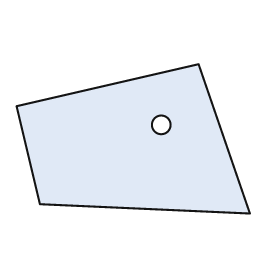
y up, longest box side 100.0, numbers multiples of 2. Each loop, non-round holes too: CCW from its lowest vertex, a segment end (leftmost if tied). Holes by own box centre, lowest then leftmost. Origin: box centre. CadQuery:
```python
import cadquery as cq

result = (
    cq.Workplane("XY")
    .moveTo(50.0, -32.0)
    .lineTo(28.0, 32.0)
    .lineTo(-50.0, 14.0)
    .lineTo(-40.0, -28.0)
    .close()
    .moveTo(12.0, 6.0)
    .circle(4.0)
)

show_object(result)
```